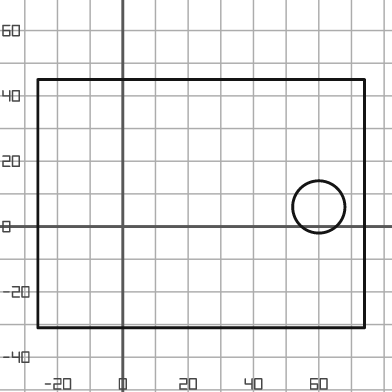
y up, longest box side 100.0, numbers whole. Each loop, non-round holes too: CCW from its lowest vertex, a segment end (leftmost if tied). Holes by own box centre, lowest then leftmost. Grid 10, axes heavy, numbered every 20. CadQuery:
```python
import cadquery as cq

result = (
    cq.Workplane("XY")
    .moveTo(-26.0, -31.0)
    .lineTo(74.0, -31.0)
    .lineTo(74.0, 45.0)
    .lineTo(-26.0, 45.0)
    .close()
    .moveTo(60.0, 6.0)
    .circle(8.0)
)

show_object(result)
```